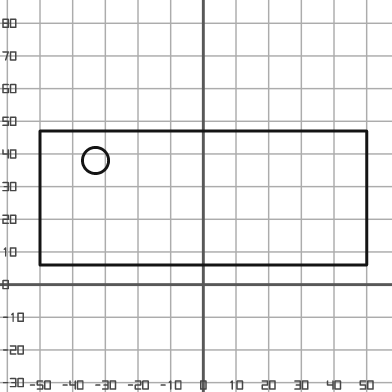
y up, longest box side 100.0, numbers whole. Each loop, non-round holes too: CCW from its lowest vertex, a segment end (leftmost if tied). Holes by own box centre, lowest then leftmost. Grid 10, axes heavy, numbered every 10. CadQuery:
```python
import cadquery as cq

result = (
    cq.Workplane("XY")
    .moveTo(-50.0, 6.0)
    .lineTo(50.0, 6.0)
    .lineTo(50.0, 47.0)
    .lineTo(-50.0, 47.0)
    .close()
    .moveTo(-33.0, 38.0)
    .circle(4.0)
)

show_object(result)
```